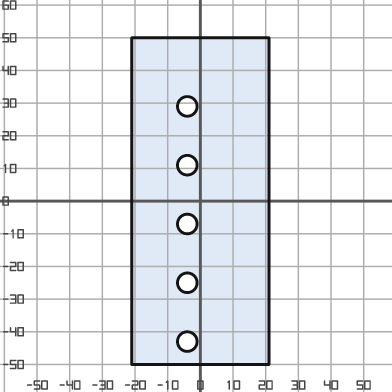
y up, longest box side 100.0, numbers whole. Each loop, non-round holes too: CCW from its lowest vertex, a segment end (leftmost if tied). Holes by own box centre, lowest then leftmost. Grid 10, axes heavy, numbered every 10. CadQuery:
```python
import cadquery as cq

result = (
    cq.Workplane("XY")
    .moveTo(-21.0, -50.0)
    .lineTo(21.0, -50.0)
    .lineTo(21.0, 50.0)
    .lineTo(-21.0, 50.0)
    .close()
    .moveTo(-4.0, -43.0)
    .circle(3.0)
    .moveTo(-4.0, -25.0)
    .circle(3.0)
    .moveTo(-4.0, -7.0)
    .circle(3.0)
    .moveTo(-4.0, 11.0)
    .circle(3.0)
    .moveTo(-4.0, 29.0)
    .circle(3.0)
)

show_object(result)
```